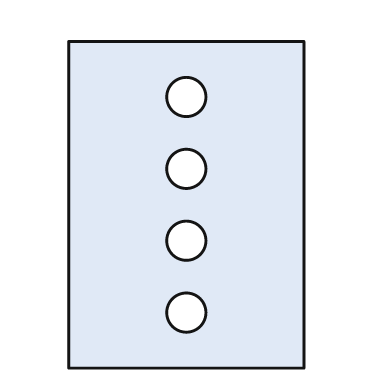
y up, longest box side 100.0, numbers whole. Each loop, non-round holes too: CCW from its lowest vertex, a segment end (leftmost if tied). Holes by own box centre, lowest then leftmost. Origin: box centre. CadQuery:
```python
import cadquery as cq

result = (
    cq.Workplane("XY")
    .moveTo(-36.0, -50.0)
    .lineTo(36.0, -50.0)
    .lineTo(36.0, 50.0)
    .lineTo(-36.0, 50.0)
    .close()
    .moveTo(0.0, -33.0)
    .circle(6.0)
    .moveTo(0.0, -11.0)
    .circle(6.0)
    .moveTo(0.0, 11.0)
    .circle(6.0)
    .moveTo(0.0, 33.0)
    .circle(6.0)
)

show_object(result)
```